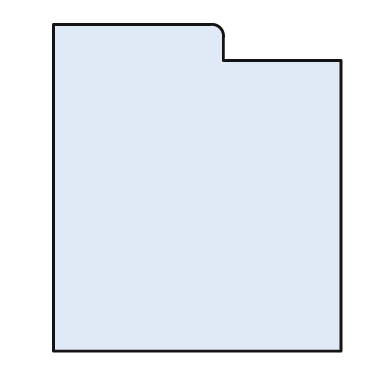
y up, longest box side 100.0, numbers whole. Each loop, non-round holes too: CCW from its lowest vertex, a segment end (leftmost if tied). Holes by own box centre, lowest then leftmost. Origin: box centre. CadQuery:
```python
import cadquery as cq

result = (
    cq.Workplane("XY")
    .moveTo(-44.0, -50.0)
    .lineTo(44.0, -50.0)
    .lineTo(44.0, 39.0)
    .lineTo(8.0, 39.0)
    .lineTo(8.0, 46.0)
    .threePointArc((7.0, 49.0), (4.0, 50.0))
    .lineTo(-44.0, 50.0)
    .close()
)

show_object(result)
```